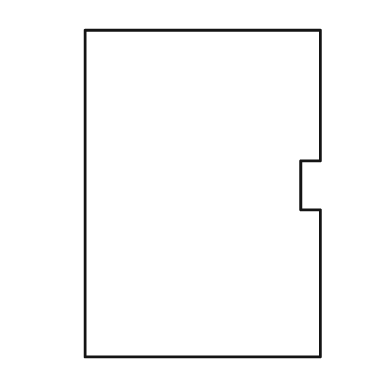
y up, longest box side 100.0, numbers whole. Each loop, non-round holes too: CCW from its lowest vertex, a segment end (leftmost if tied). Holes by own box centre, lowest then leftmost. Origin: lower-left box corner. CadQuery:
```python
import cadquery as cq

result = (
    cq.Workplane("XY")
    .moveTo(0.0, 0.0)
    .lineTo(72.0, 0.0)
    .lineTo(72.0, 45.0)
    .lineTo(66.0, 45.0)
    .lineTo(66.0, 60.0)
    .lineTo(72.0, 60.0)
    .lineTo(72.0, 100.0)
    .lineTo(0.0, 100.0)
    .close()
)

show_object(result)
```